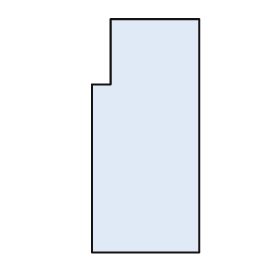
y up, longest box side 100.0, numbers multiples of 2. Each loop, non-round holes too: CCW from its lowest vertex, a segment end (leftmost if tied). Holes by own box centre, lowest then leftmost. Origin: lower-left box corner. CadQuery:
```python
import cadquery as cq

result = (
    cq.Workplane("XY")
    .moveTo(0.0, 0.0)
    .lineTo(46.0, 0.0)
    .lineTo(46.0, 100.0)
    .lineTo(8.0, 100.0)
    .lineTo(8.0, 72.0)
    .lineTo(0.0, 72.0)
    .close()
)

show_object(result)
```